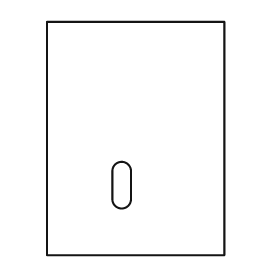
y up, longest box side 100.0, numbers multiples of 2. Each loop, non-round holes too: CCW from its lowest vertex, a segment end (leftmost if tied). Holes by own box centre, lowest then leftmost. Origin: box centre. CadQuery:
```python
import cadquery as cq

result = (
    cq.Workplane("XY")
    .moveTo(-38.0, -50.0)
    .lineTo(38.0, -50.0)
    .lineTo(38.0, 50.0)
    .lineTo(-38.0, 50.0)
    .close()
    .moveTo(-10.0, -26.0)
    .threePointArc((-6.0, -30.0), (-2.0, -26.0))
    .lineTo(-2.0, -14.0)
    .threePointArc((-6.0, -10.0), (-10.0, -14.0))
    .close()
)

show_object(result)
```